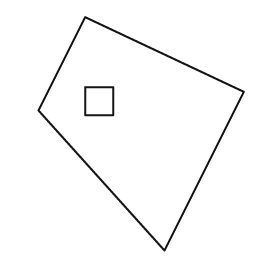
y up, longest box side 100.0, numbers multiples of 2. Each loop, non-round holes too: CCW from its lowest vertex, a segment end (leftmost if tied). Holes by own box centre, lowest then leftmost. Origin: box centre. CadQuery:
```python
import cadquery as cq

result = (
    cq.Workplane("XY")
    .moveTo(10.0, -50.0)
    .lineTo(44.0, 18.0)
    .lineTo(-24.0, 50.0)
    .lineTo(-44.0, 10.0)
    .close()
    .moveTo(-24.0, 8.0)
    .lineTo(-12.0, 8.0)
    .lineTo(-12.0, 20.0)
    .lineTo(-24.0, 20.0)
    .close()
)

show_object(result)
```